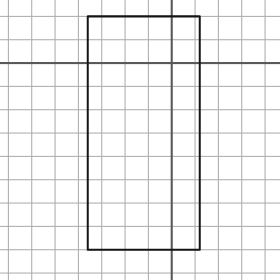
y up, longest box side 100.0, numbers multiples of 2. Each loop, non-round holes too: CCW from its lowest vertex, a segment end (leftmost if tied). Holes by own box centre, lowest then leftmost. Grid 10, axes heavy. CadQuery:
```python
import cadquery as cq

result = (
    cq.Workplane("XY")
    .moveTo(-36.0, -80.0)
    .lineTo(12.0, -80.0)
    .lineTo(12.0, 20.0)
    .lineTo(-36.0, 20.0)
    .close()
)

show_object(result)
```